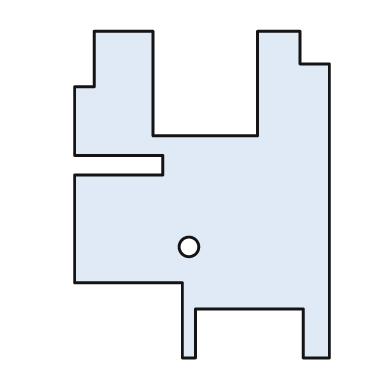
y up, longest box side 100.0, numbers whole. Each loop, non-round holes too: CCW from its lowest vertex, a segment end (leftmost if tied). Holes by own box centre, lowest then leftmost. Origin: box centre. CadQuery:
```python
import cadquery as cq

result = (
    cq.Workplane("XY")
    .moveTo(-6.0, -50.0)
    .lineTo(-2.0, -50.0)
    .lineTo(-2.0, -35.0)
    .lineTo(31.0, -35.0)
    .lineTo(31.0, -50.0)
    .lineTo(39.0, -50.0)
    .lineTo(39.0, 40.0)
    .lineTo(30.0, 40.0)
    .lineTo(30.0, 50.0)
    .lineTo(17.0, 50.0)
    .lineTo(17.0, 18.0)
    .lineTo(-15.0, 18.0)
    .lineTo(-15.0, 50.0)
    .lineTo(-33.0, 50.0)
    .lineTo(-33.0, 33.0)
    .lineTo(-39.0, 33.0)
    .lineTo(-39.0, 12.0)
    .lineTo(-12.0, 12.0)
    .lineTo(-12.0, 6.0)
    .lineTo(-39.0, 6.0)
    .lineTo(-39.0, -27.0)
    .lineTo(-6.0, -27.0)
    .close()
    .moveTo(-4.0, -16.0)
    .circle(3.0)
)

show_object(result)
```